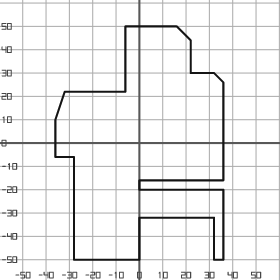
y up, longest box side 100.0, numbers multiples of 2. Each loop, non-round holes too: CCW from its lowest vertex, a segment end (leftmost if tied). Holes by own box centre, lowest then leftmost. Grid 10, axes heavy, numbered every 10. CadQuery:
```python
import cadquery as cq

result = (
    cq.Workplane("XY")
    .moveTo(-28.0, -50.0)
    .lineTo(0.0, -50.0)
    .lineTo(0.0, -32.0)
    .lineTo(32.0, -32.0)
    .lineTo(32.0, -50.0)
    .lineTo(36.0, -50.0)
    .lineTo(36.0, -20.0)
    .lineTo(0.0, -20.0)
    .lineTo(0.0, -16.0)
    .lineTo(36.0, -16.0)
    .lineTo(36.0, 26.0)
    .lineTo(32.0, 30.0)
    .lineTo(22.0, 30.0)
    .lineTo(22.0, 44.0)
    .lineTo(16.0, 50.0)
    .lineTo(-6.0, 50.0)
    .lineTo(-6.0, 22.0)
    .lineTo(-32.0, 22.0)
    .lineTo(-36.0, 10.0)
    .lineTo(-36.0, -6.0)
    .lineTo(-28.0, -6.0)
    .close()
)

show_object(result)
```